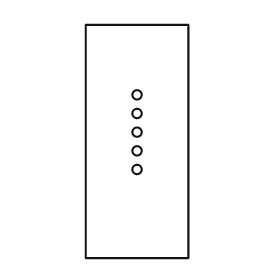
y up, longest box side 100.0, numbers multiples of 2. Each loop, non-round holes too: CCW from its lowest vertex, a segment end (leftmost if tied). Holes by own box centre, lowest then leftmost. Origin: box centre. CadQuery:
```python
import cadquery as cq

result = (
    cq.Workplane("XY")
    .moveTo(-22.0, -50.0)
    .lineTo(22.0, -50.0)
    .lineTo(22.0, 50.0)
    .lineTo(-22.0, 50.0)
    .close()
    .moveTo(0.0, -12.0)
    .circle(2.0)
    .moveTo(0.0, -4.0)
    .circle(2.0)
    .moveTo(0.0, 4.0)
    .circle(2.0)
    .moveTo(0.0, 12.0)
    .circle(2.0)
    .moveTo(0.0, 20.0)
    .circle(2.0)
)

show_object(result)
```